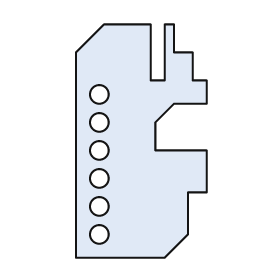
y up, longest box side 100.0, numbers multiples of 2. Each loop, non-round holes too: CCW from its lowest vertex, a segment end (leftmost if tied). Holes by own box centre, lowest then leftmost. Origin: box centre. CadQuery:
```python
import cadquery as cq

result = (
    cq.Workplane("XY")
    .moveTo(-28.0, -50.0)
    .lineTo(10.0, -50.0)
    .lineTo(20.0, -40.0)
    .lineTo(20.0, -22.0)
    .lineTo(28.0, -22.0)
    .lineTo(28.0, -4.0)
    .lineTo(6.0, -4.0)
    .lineTo(6.0, 8.0)
    .lineTo(14.0, 16.0)
    .lineTo(28.0, 16.0)
    .lineTo(28.0, 26.0)
    .lineTo(22.0, 26.0)
    .lineTo(22.0, 38.0)
    .lineTo(14.0, 38.0)
    .lineTo(14.0, 50.0)
    .lineTo(10.0, 50.0)
    .lineTo(10.0, 26.0)
    .lineTo(4.0, 26.0)
    .lineTo(4.0, 50.0)
    .lineTo(-16.0, 50.0)
    .lineTo(-28.0, 38.0)
    .close()
    .moveTo(-18.0, -40.0)
    .circle(4.0)
    .moveTo(-18.0, -28.0)
    .circle(4.0)
    .moveTo(-18.0, -16.0)
    .circle(4.0)
    .moveTo(-18.0, -4.0)
    .circle(4.0)
    .moveTo(-18.0, 8.0)
    .circle(4.0)
    .moveTo(-18.0, 20.0)
    .circle(4.0)
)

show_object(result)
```